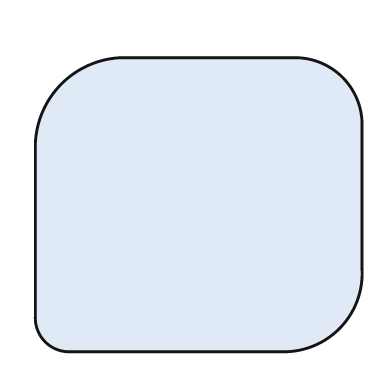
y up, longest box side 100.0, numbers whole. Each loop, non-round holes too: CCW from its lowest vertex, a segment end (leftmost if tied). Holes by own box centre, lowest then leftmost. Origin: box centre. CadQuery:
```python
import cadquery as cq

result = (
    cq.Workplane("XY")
    .moveTo(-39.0, -45.0)
    .lineTo(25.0, -45.0)
    .threePointArc((43.0, -38.0), (50.0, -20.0))
    .lineTo(50.0, 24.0)
    .threePointArc((44.0, 39.0), (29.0, 45.0))
    .lineTo(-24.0, 45.0)
    .threePointArc((-42.0, 37.0), (-50.0, 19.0))
    .lineTo(-50.0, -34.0)
    .threePointArc((-47.0, -42.0), (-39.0, -45.0))
    .close()
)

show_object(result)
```